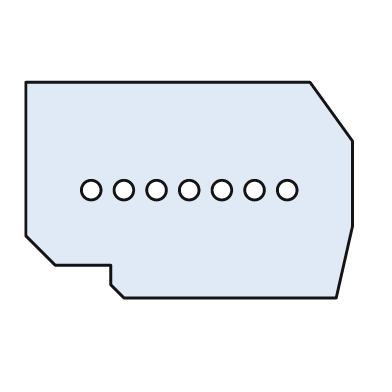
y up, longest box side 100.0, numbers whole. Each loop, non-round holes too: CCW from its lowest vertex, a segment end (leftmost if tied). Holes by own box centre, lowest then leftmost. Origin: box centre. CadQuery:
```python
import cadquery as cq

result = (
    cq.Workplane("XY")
    .moveTo(-20.0, -33.0)
    .lineTo(45.0, -33.0)
    .lineTo(50.0, -11.0)
    .lineTo(50.0, 15.0)
    .lineTo(37.0, 33.0)
    .lineTo(-50.0, 33.0)
    .lineTo(-50.0, -14.0)
    .lineTo(-41.0, -23.0)
    .lineTo(-24.0, -23.0)
    .lineTo(-24.0, -29.0)
    .close()
    .moveTo(-30.0, 0.0)
    .circle(3.0)
    .moveTo(-20.0, 0.0)
    .circle(3.0)
    .moveTo(-10.0, 0.0)
    .circle(3.0)
    .moveTo(0.0, 0.0)
    .circle(3.0)
    .moveTo(10.0, 0.0)
    .circle(3.0)
    .moveTo(20.0, 0.0)
    .circle(3.0)
    .moveTo(30.0, 0.0)
    .circle(3.0)
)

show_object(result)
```